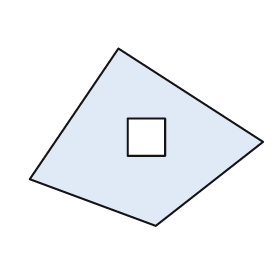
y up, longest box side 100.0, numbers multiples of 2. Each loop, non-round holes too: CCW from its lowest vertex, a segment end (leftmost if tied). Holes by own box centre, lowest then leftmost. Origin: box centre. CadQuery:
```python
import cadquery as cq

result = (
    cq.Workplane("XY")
    .moveTo(4.0, -38.0)
    .lineTo(50.0, -2.0)
    .lineTo(-12.0, 38.0)
    .lineTo(-50.0, -18.0)
    .close()
    .moveTo(-8.0, -8.0)
    .lineTo(8.0, -8.0)
    .lineTo(8.0, 8.0)
    .lineTo(-8.0, 8.0)
    .close()
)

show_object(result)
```